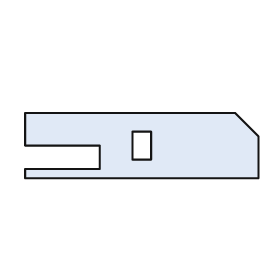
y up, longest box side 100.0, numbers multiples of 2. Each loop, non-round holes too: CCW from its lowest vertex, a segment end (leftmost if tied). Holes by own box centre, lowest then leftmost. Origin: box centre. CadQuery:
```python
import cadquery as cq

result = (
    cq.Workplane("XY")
    .moveTo(-50.0, -14.0)
    .lineTo(50.0, -14.0)
    .lineTo(50.0, 4.0)
    .lineTo(40.0, 14.0)
    .lineTo(-50.0, 14.0)
    .lineTo(-50.0, 0.0)
    .lineTo(-18.0, 0.0)
    .lineTo(-18.0, -10.0)
    .lineTo(-50.0, -10.0)
    .close()
    .moveTo(-4.0, -6.0)
    .lineTo(4.0, -6.0)
    .lineTo(4.0, 6.0)
    .lineTo(-4.0, 6.0)
    .close()
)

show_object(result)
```